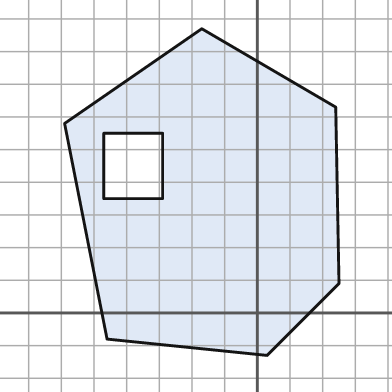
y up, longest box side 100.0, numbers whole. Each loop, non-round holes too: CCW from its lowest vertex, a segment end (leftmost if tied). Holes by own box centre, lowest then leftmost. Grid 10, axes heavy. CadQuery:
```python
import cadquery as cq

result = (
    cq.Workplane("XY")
    .moveTo(3.0, -13.0)
    .lineTo(25.0, 9.0)
    .lineTo(24.0, 63.0)
    .lineTo(-17.0, 87.0)
    .lineTo(-59.0, 58.0)
    .lineTo(-46.0, -8.0)
    .close()
    .moveTo(-47.0, 35.0)
    .lineTo(-29.0, 35.0)
    .lineTo(-29.0, 55.0)
    .lineTo(-47.0, 55.0)
    .close()
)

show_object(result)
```